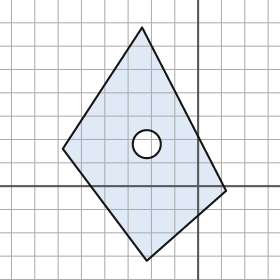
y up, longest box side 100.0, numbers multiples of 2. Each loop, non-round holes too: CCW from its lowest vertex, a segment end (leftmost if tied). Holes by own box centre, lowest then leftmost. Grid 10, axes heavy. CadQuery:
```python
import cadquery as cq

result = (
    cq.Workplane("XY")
    .moveTo(-22.0, -32.0)
    .lineTo(12.0, -2.0)
    .lineTo(-24.0, 68.0)
    .lineTo(-58.0, 16.0)
    .close()
    .moveTo(-22.0, 18.0)
    .circle(6.0)
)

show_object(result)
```